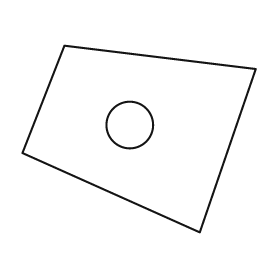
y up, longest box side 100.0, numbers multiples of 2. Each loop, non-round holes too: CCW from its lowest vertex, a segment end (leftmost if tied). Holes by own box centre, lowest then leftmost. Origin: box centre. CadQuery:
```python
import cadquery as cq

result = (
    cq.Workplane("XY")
    .moveTo(26.0, -40.0)
    .lineTo(50.0, 30.0)
    .lineTo(-32.0, 40.0)
    .lineTo(-50.0, -6.0)
    .close()
    .moveTo(-4.0, 6.0)
    .circle(10.0)
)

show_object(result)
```